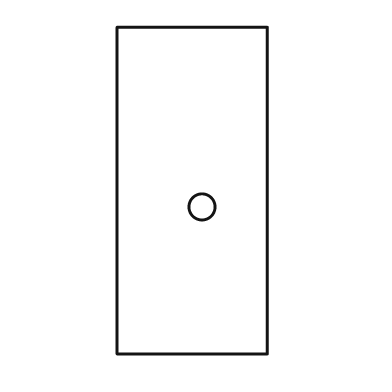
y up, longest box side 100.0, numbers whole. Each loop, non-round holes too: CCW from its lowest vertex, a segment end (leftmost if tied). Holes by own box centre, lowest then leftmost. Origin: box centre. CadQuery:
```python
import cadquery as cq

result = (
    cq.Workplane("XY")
    .moveTo(-23.0, -50.0)
    .lineTo(23.0, -50.0)
    .lineTo(23.0, 50.0)
    .lineTo(-23.0, 50.0)
    .close()
    .moveTo(3.0, -5.0)
    .circle(4.0)
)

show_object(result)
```